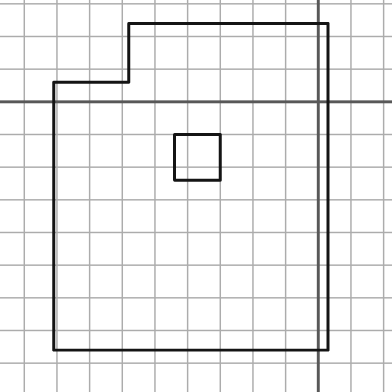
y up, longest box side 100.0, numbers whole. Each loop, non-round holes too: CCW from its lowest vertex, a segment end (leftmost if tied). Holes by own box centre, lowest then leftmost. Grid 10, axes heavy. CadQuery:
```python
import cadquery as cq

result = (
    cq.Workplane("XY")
    .moveTo(-81.0, -76.0)
    .lineTo(3.0, -76.0)
    .lineTo(3.0, 24.0)
    .lineTo(-58.0, 24.0)
    .lineTo(-58.0, 6.0)
    .lineTo(-81.0, 6.0)
    .close()
    .moveTo(-44.0, -24.0)
    .lineTo(-30.0, -24.0)
    .lineTo(-30.0, -10.0)
    .lineTo(-44.0, -10.0)
    .close()
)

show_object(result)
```